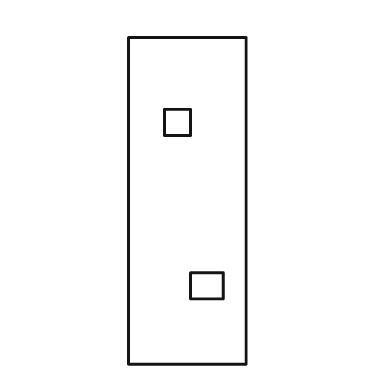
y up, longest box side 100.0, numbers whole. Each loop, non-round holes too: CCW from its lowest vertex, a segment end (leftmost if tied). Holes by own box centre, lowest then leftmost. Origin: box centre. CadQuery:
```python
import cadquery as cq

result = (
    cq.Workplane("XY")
    .moveTo(-18.0, -50.0)
    .lineTo(18.0, -50.0)
    .lineTo(18.0, 50.0)
    .lineTo(-18.0, 50.0)
    .close()
    .moveTo(1.0, -30.0)
    .lineTo(11.0, -30.0)
    .lineTo(11.0, -22.0)
    .lineTo(1.0, -22.0)
    .close()
    .moveTo(-7.0, 20.0)
    .lineTo(1.0, 20.0)
    .lineTo(1.0, 28.0)
    .lineTo(-7.0, 28.0)
    .close()
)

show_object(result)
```